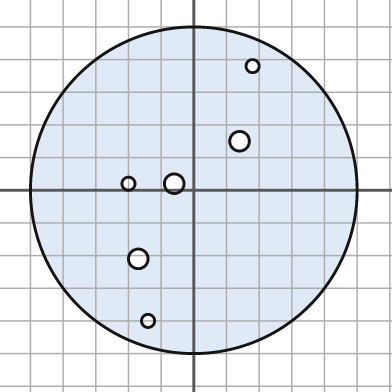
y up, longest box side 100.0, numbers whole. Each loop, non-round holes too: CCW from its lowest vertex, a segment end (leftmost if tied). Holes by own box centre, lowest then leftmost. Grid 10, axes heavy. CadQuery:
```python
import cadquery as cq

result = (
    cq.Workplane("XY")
    .moveTo(0.0, 0.0)
    .circle(50.0)
    .moveTo(-14.0, -40.0)
    .circle(2.0)
    .moveTo(-17.0, -21.0)
    .circle(3.0)
    .moveTo(-20.0, 2.0)
    .circle(2.0)
    .moveTo(-6.0, 2.0)
    .circle(3.0)
    .moveTo(14.0, 15.0)
    .circle(3.0)
    .moveTo(18.0, 38.0)
    .circle(2.0)
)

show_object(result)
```